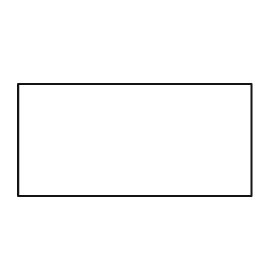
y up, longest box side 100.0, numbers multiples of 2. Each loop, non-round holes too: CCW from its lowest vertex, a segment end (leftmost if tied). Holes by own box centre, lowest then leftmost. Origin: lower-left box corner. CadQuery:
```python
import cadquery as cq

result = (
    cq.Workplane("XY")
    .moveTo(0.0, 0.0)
    .lineTo(100.0, 0.0)
    .lineTo(100.0, 48.0)
    .lineTo(0.0, 48.0)
    .close()
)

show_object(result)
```